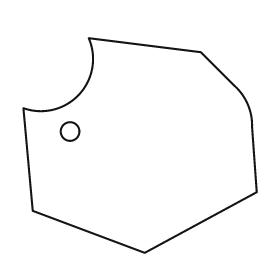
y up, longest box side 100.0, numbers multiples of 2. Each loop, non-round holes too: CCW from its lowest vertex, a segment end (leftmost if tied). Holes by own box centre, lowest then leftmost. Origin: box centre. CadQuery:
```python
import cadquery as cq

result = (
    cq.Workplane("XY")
    .moveTo(2.0, -46.0)
    .lineTo(50.0, -20.0)
    .lineTo(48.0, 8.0)
    .threePointArc((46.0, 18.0), (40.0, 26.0))
    .lineTo(26.0, 40.0)
    .lineTo(-22.0, 46.0)
    .threePointArc((-26.0, 22.0), (-50.0, 16.0))
    .lineTo(-46.0, -28.0)
    .close()
    .moveTo(-30.0, 6.0)
    .circle(4.0)
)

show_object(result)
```